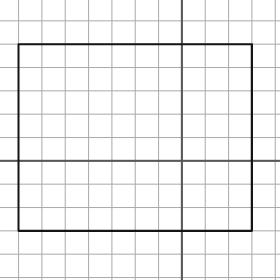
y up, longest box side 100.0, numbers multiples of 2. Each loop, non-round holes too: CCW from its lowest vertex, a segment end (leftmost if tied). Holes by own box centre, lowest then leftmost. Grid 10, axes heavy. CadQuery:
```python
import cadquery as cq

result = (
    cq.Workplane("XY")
    .moveTo(-70.0, -30.0)
    .lineTo(30.0, -30.0)
    .lineTo(30.0, 50.0)
    .lineTo(-70.0, 50.0)
    .close()
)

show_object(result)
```